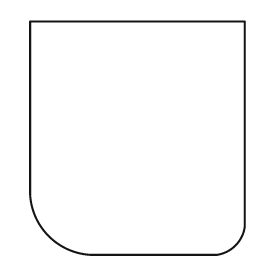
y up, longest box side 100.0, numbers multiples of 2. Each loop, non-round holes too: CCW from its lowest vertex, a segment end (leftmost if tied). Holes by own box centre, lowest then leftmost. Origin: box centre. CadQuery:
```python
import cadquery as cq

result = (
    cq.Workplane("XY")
    .moveTo(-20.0, -50.0)
    .lineTo(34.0, -50.0)
    .threePointArc((42.0, -46.0), (46.0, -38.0))
    .lineTo(46.0, 50.0)
    .lineTo(-46.0, 50.0)
    .lineTo(-46.0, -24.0)
    .threePointArc((-38.0, -42.0), (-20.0, -50.0))
    .close()
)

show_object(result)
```